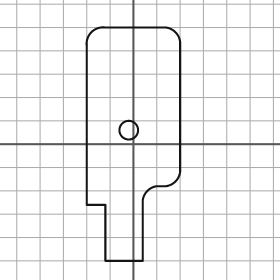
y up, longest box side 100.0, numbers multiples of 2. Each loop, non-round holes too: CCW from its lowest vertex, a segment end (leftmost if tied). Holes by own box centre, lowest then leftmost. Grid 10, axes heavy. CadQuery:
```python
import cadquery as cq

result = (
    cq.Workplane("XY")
    .moveTo(-12.0, -50.0)
    .lineTo(4.0, -50.0)
    .lineTo(4.0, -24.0)
    .threePointArc((6.0, -20.0), (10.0, -18.0))
    .lineTo(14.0, -18.0)
    .threePointArc((18.0, -16.0), (20.0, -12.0))
    .lineTo(20.0, 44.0)
    .threePointArc((18.0, 48.0), (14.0, 50.0))
    .lineTo(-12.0, 50.0)
    .threePointArc((-18.0, 48.0), (-20.0, 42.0))
    .lineTo(-20.0, -26.0)
    .lineTo(-12.0, -26.0)
    .close()
    .moveTo(-2.0, 6.0)
    .circle(4.0)
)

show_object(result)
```